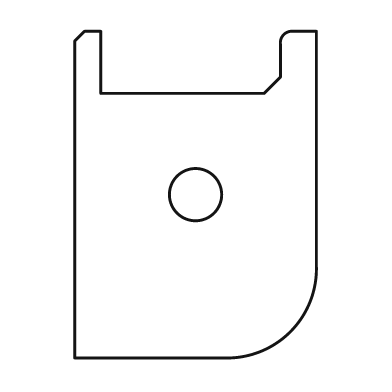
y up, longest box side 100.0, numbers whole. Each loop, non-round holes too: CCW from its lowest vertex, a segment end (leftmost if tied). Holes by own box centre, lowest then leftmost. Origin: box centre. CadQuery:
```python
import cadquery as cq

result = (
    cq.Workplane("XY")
    .moveTo(-37.0, -50.0)
    .lineTo(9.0, -50.0)
    .threePointArc((29.0, -42.0), (37.0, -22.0))
    .lineTo(37.0, 50.0)
    .lineTo(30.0, 50.0)
    .threePointArc((27.0, 49.0), (26.0, 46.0))
    .lineTo(26.0, 36.0)
    .lineTo(21.0, 31.0)
    .lineTo(-29.0, 31.0)
    .lineTo(-29.0, 50.0)
    .lineTo(-34.0, 50.0)
    .lineTo(-37.0, 47.0)
    .close()
    .moveTo(0.0, 0.0)
    .circle(8.0)
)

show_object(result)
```